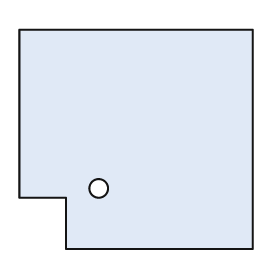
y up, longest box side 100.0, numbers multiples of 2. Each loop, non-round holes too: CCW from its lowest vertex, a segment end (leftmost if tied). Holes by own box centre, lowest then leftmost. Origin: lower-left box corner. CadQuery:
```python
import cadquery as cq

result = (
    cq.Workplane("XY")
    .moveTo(20.0, 0.0)
    .lineTo(100.0, 0.0)
    .lineTo(100.0, 94.0)
    .lineTo(0.0, 94.0)
    .lineTo(0.0, 22.0)
    .lineTo(20.0, 22.0)
    .close()
    .moveTo(34.0, 26.0)
    .circle(4.0)
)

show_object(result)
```